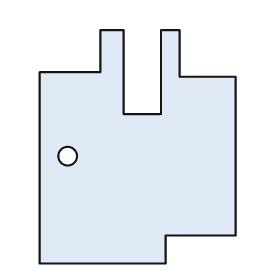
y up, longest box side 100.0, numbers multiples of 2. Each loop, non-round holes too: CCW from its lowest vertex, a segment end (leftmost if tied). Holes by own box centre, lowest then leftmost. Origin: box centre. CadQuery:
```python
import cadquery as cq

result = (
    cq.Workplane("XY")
    .moveTo(-42.0, -50.0)
    .lineTo(12.0, -50.0)
    .lineTo(12.0, -38.0)
    .lineTo(42.0, -38.0)
    .lineTo(42.0, 30.0)
    .lineTo(18.0, 30.0)
    .lineTo(18.0, 50.0)
    .lineTo(10.0, 50.0)
    .lineTo(10.0, 14.0)
    .lineTo(-6.0, 14.0)
    .lineTo(-6.0, 50.0)
    .lineTo(-16.0, 50.0)
    .lineTo(-16.0, 32.0)
    .lineTo(-42.0, 32.0)
    .close()
    .moveTo(-30.0, -4.0)
    .circle(4.0)
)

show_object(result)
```